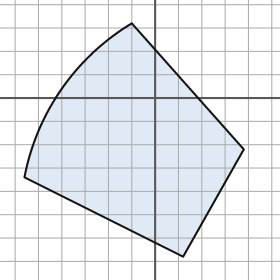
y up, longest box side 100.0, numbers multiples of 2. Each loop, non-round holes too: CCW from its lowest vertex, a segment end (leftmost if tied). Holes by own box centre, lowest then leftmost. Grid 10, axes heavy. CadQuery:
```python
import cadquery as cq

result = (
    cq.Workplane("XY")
    .moveTo(12.0, -68.0)
    .lineTo(38.0, -22.0)
    .lineTo(-10.0, 32.0)
    .threePointArc((-40.0, 4.0), (-56.0, -34.0))
    .close()
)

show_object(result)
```